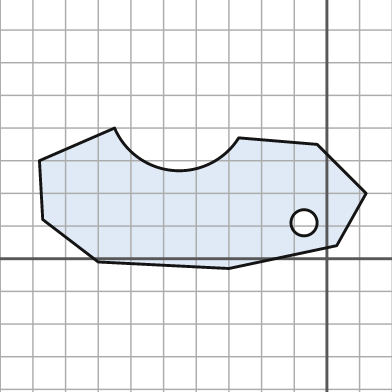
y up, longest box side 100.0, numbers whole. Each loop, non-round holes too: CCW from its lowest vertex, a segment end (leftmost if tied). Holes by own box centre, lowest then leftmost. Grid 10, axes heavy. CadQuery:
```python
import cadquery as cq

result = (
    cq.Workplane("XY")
    .moveTo(-30.0, -3.0)
    .lineTo(3.0, 4.0)
    .lineTo(12.0, 20.0)
    .lineTo(-3.0, 35.0)
    .lineTo(-27.0, 37.0)
    .threePointArc((-47.0, 27.0), (-65.0, 40.0))
    .lineTo(-88.0, 30.0)
    .lineTo(-87.0, 12.0)
    .lineTo(-70.0, -1.0)
    .close()
    .moveTo(-7.0, 11.0)
    .circle(4.0)
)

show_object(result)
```